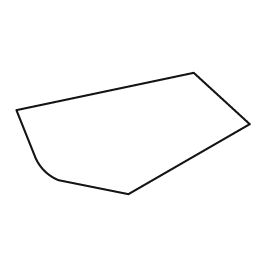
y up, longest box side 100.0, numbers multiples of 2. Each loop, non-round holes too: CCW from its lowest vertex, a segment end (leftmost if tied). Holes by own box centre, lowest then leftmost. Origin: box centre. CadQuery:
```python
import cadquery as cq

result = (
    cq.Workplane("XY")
    .moveTo(-2.0, -26.0)
    .lineTo(50.0, 4.0)
    .lineTo(26.0, 26.0)
    .lineTo(-50.0, 10.0)
    .lineTo(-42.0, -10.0)
    .threePointArc((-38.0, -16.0), (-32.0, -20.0))
    .close()
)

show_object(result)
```